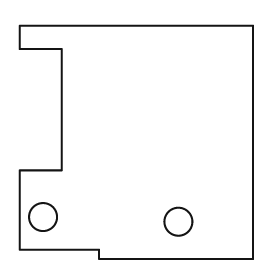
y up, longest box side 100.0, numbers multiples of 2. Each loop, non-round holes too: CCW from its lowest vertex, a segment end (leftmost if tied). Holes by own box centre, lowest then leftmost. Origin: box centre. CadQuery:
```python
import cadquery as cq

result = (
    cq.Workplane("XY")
    .moveTo(-16.0, -50.0)
    .lineTo(50.0, -50.0)
    .lineTo(50.0, 50.0)
    .lineTo(-50.0, 50.0)
    .lineTo(-50.0, 40.0)
    .lineTo(-32.0, 40.0)
    .lineTo(-32.0, -12.0)
    .lineTo(-50.0, -12.0)
    .lineTo(-50.0, -46.0)
    .lineTo(-16.0, -46.0)
    .close()
    .moveTo(18.0, -34.0)
    .circle(6.0)
    .moveTo(-40.0, -32.0)
    .circle(6.0)
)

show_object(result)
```